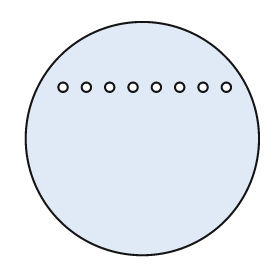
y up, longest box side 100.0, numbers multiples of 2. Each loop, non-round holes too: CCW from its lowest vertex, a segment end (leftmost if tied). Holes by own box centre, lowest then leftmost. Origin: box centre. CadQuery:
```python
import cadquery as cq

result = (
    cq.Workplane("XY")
    .moveTo(0.0, 0.0)
    .circle(50.0)
    .moveTo(-34.0, 22.0)
    .circle(2.0)
    .moveTo(-24.0, 22.0)
    .circle(2.0)
    .moveTo(-14.0, 22.0)
    .circle(2.0)
    .moveTo(-4.0, 22.0)
    .circle(2.0)
    .moveTo(6.0, 22.0)
    .circle(2.0)
    .moveTo(16.0, 22.0)
    .circle(2.0)
    .moveTo(26.0, 22.0)
    .circle(2.0)
    .moveTo(36.0, 22.0)
    .circle(2.0)
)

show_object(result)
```